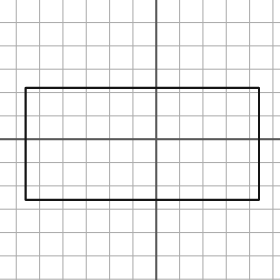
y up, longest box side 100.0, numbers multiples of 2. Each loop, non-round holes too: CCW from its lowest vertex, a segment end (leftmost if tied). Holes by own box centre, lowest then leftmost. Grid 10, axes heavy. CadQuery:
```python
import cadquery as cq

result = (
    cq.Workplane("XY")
    .moveTo(-56.0, -26.0)
    .lineTo(44.0, -26.0)
    .lineTo(44.0, 22.0)
    .lineTo(-56.0, 22.0)
    .close()
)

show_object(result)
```